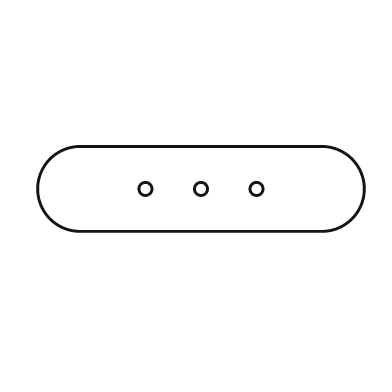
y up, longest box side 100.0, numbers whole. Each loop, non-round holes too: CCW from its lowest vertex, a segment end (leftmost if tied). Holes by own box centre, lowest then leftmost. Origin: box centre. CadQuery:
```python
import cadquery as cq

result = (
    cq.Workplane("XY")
    .moveTo(-37.0, -13.0)
    .lineTo(37.0, -13.0)
    .threePointArc((50.0, 0.0), (37.0, 13.0))
    .lineTo(-37.0, 13.0)
    .threePointArc((-50.0, 0.0), (-37.0, -13.0))
    .close()
    .moveTo(-17.0, 0.0)
    .circle(2.0)
    .moveTo(0.0, 0.0)
    .circle(2.0)
    .moveTo(17.0, 0.0)
    .circle(2.0)
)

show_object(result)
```